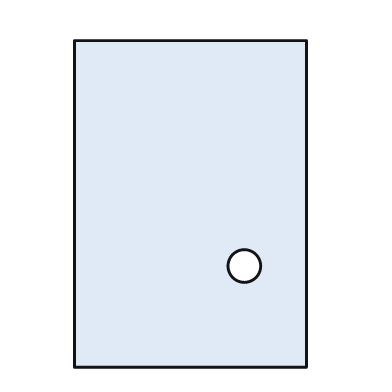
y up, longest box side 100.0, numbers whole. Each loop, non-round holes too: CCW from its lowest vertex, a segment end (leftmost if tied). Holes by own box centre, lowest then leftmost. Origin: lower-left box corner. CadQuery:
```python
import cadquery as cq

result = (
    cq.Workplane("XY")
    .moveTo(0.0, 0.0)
    .lineTo(71.0, 0.0)
    .lineTo(71.0, 100.0)
    .lineTo(0.0, 100.0)
    .close()
    .moveTo(52.0, 31.0)
    .circle(5.0)
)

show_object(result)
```